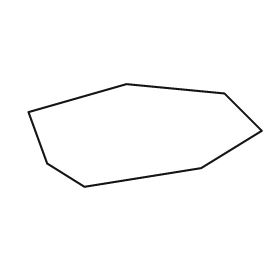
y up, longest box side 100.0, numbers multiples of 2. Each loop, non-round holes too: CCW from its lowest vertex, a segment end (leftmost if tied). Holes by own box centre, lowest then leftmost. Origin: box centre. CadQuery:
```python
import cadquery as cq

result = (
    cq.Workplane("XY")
    .moveTo(-26.0, -22.0)
    .lineTo(24.0, -14.0)
    .lineTo(50.0, 2.0)
    .lineTo(34.0, 18.0)
    .lineTo(-8.0, 22.0)
    .lineTo(-50.0, 10.0)
    .lineTo(-42.0, -12.0)
    .close()
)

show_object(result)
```